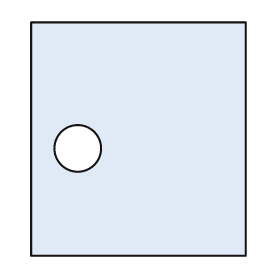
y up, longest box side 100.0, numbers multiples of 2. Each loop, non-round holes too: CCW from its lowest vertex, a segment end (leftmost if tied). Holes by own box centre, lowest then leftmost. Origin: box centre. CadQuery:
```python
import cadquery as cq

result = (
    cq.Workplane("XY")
    .moveTo(-46.0, -50.0)
    .lineTo(46.0, -50.0)
    .lineTo(46.0, 50.0)
    .lineTo(-46.0, 50.0)
    .close()
    .moveTo(-26.0, -4.0)
    .circle(10.0)
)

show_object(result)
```